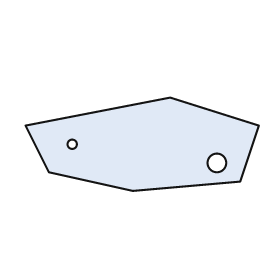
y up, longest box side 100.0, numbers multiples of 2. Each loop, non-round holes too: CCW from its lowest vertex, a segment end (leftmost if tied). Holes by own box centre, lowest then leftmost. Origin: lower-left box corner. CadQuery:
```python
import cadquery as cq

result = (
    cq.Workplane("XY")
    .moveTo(46.0, 0.0)
    .lineTo(92.0, 4.0)
    .lineTo(100.0, 28.0)
    .lineTo(62.0, 40.0)
    .lineTo(0.0, 28.0)
    .lineTo(10.0, 8.0)
    .close()
    .moveTo(82.0, 12.0)
    .circle(4.0)
    .moveTo(20.0, 20.0)
    .circle(2.0)
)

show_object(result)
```